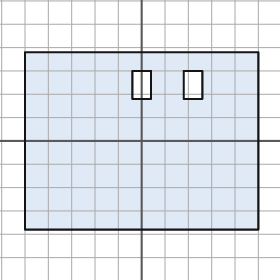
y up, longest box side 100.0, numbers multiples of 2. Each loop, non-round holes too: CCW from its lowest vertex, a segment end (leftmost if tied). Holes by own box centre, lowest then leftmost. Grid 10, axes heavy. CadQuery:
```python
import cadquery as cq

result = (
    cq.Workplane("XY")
    .moveTo(-50.0, -38.0)
    .lineTo(50.0, -38.0)
    .lineTo(50.0, 38.0)
    .lineTo(-50.0, 38.0)
    .close()
    .moveTo(-4.0, 18.0)
    .lineTo(4.0, 18.0)
    .lineTo(4.0, 30.0)
    .lineTo(-4.0, 30.0)
    .close()
    .moveTo(18.0, 18.0)
    .lineTo(26.0, 18.0)
    .lineTo(26.0, 30.0)
    .lineTo(18.0, 30.0)
    .close()
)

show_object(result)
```